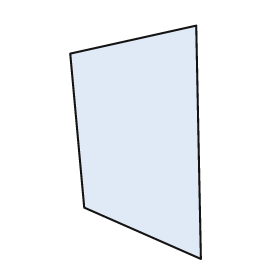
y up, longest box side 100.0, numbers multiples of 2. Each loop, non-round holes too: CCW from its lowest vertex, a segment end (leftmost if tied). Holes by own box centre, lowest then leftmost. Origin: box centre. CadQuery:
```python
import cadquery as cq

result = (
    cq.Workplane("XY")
    .moveTo(28.0, -50.0)
    .lineTo(26.0, 50.0)
    .lineTo(-28.0, 38.0)
    .lineTo(-22.0, -28.0)
    .close()
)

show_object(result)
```